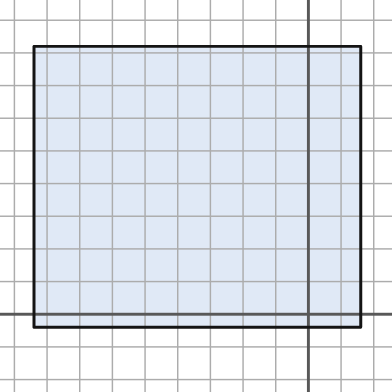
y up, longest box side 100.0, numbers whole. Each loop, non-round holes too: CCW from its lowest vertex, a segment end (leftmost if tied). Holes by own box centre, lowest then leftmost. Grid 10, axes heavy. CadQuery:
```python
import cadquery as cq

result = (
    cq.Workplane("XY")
    .moveTo(-84.0, -4.0)
    .lineTo(16.0, -4.0)
    .lineTo(16.0, 82.0)
    .lineTo(-84.0, 82.0)
    .close()
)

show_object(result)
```